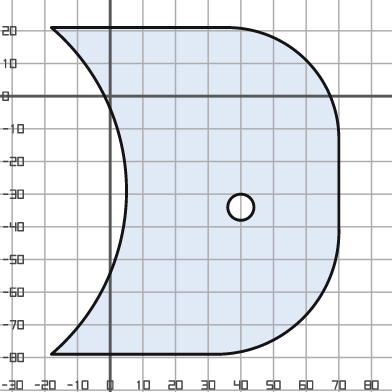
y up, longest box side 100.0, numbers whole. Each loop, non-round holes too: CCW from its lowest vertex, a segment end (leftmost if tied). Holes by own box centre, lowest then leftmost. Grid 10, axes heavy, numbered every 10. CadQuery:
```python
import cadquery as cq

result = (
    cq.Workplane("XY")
    .moveTo(-18.0, -79.0)
    .lineTo(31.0, -79.0)
    .threePointArc((59.0, -68.0), (70.0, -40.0))
    .lineTo(70.0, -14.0)
    .threePointArc((60.0, 11.0), (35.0, 21.0))
    .lineTo(-18.0, 21.0)
    .threePointArc((5.0, -29.0), (-18.0, -79.0))
    .close()
    .moveTo(40.0, -34.0)
    .circle(4.0)
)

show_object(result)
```